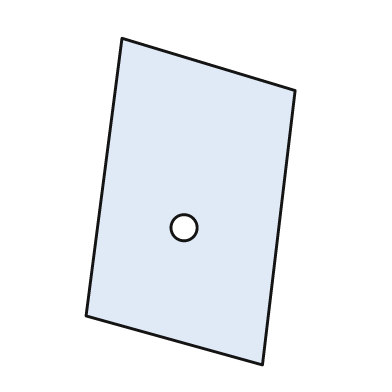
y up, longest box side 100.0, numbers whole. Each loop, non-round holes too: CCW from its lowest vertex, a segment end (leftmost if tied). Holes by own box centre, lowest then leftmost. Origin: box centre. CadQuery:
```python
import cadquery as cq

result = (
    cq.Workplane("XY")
    .moveTo(22.0, -50.0)
    .lineTo(32.0, 34.0)
    .lineTo(-21.0, 50.0)
    .lineTo(-32.0, -35.0)
    .close()
    .moveTo(-2.0, -8.0)
    .circle(4.0)
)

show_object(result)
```